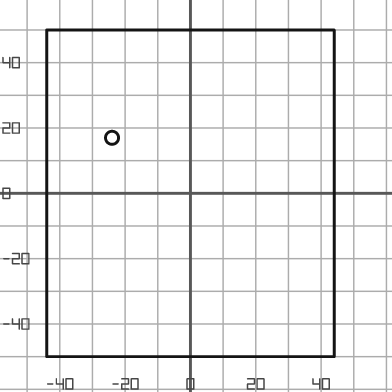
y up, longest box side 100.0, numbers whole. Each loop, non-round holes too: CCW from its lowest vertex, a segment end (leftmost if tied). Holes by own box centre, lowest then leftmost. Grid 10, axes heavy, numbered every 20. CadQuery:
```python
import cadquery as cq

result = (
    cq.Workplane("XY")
    .moveTo(-44.0, -50.0)
    .lineTo(44.0, -50.0)
    .lineTo(44.0, 50.0)
    .lineTo(-44.0, 50.0)
    .close()
    .moveTo(-24.0, 17.0)
    .circle(2.0)
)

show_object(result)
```